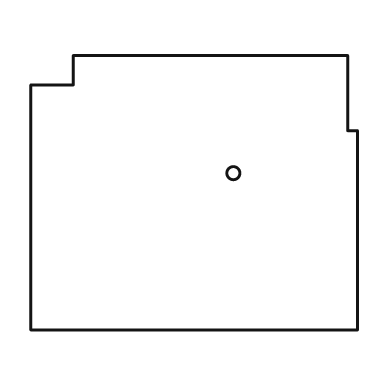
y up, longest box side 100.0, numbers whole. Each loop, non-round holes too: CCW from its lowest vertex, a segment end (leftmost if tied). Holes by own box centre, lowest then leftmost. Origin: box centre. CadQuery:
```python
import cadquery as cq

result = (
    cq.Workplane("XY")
    .moveTo(-50.0, -42.0)
    .lineTo(50.0, -42.0)
    .lineTo(50.0, 19.0)
    .lineTo(47.0, 19.0)
    .lineTo(47.0, 42.0)
    .lineTo(-37.0, 42.0)
    .lineTo(-37.0, 33.0)
    .lineTo(-50.0, 33.0)
    .close()
    .moveTo(12.0, 6.0)
    .circle(2.0)
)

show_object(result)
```